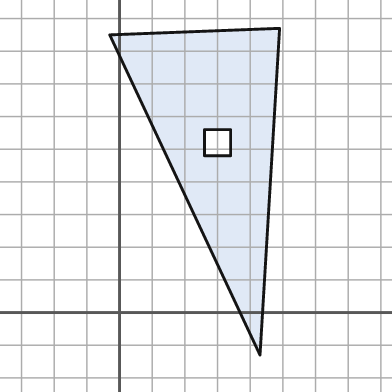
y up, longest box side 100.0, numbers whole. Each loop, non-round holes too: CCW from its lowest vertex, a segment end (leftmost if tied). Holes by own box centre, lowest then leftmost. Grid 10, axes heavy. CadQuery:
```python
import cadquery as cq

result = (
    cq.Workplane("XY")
    .moveTo(43.0, -13.0)
    .lineTo(49.0, 87.0)
    .lineTo(-3.0, 85.0)
    .close()
    .moveTo(26.0, 48.0)
    .lineTo(34.0, 48.0)
    .lineTo(34.0, 56.0)
    .lineTo(26.0, 56.0)
    .close()
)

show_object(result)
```